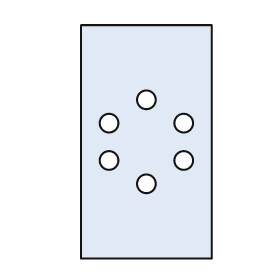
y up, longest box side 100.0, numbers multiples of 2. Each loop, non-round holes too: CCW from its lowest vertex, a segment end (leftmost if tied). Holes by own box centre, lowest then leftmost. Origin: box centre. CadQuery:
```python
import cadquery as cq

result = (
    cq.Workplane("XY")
    .moveTo(-28.0, -50.0)
    .lineTo(28.0, -50.0)
    .lineTo(28.0, 50.0)
    .lineTo(-28.0, 50.0)
    .close()
    .moveTo(0.0, -18.0)
    .circle(4.0)
    .moveTo(-16.0, -8.0)
    .circle(4.0)
    .moveTo(16.0, -8.0)
    .circle(4.0)
    .moveTo(-16.0, 8.0)
    .circle(4.0)
    .moveTo(16.0, 8.0)
    .circle(4.0)
    .moveTo(0.0, 18.0)
    .circle(4.0)
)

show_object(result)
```